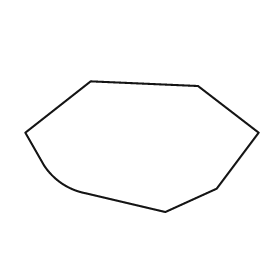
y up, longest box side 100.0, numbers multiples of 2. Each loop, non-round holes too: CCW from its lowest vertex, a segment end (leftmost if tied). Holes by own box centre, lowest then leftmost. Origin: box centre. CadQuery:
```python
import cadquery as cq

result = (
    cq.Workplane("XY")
    .moveTo(10.0, -28.0)
    .lineTo(32.0, -18.0)
    .lineTo(50.0, 6.0)
    .lineTo(24.0, 26.0)
    .lineTo(-22.0, 28.0)
    .lineTo(-50.0, 6.0)
    .lineTo(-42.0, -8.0)
    .threePointArc((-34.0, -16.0), (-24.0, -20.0))
    .close()
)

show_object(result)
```